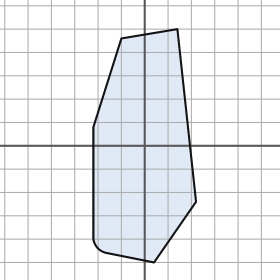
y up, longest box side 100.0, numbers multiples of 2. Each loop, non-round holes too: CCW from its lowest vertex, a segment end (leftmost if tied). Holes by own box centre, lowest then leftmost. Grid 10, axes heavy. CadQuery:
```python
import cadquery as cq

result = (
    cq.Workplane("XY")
    .moveTo(4.0, -50.0)
    .lineTo(22.0, -24.0)
    .lineTo(14.0, 50.0)
    .lineTo(-10.0, 46.0)
    .lineTo(-22.0, 8.0)
    .lineTo(-22.0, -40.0)
    .threePointArc((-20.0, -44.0), (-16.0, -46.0))
    .close()
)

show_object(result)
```